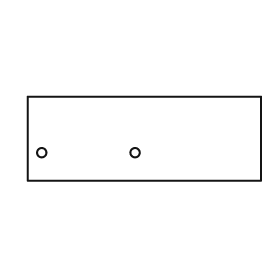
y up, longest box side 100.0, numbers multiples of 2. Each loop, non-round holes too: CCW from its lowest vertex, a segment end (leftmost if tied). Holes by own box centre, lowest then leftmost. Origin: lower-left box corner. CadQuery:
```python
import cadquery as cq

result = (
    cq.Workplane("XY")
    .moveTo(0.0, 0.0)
    .lineTo(100.0, 0.0)
    .lineTo(100.0, 36.0)
    .lineTo(0.0, 36.0)
    .close()
    .moveTo(6.0, 12.0)
    .circle(2.0)
    .moveTo(46.0, 12.0)
    .circle(2.0)
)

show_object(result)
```